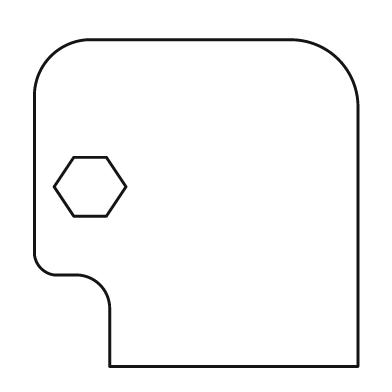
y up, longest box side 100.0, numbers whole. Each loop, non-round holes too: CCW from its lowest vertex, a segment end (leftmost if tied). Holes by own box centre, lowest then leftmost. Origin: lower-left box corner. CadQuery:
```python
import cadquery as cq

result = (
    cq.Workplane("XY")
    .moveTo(23.0, 0.0)
    .lineTo(99.0, 0.0)
    .lineTo(99.0, 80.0)
    .threePointArc((93.0, 94.0), (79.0, 100.0))
    .lineTo(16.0, 100.0)
    .threePointArc((5.0, 95.0), (0.0, 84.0))
    .lineTo(0.0, 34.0)
    .threePointArc((2.0, 30.0), (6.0, 28.0))
    .lineTo(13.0, 28.0)
    .threePointArc((20.0, 25.0), (23.0, 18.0))
    .close()
    .moveTo(12.0, 46.0)
    .lineTo(22.0, 46.0)
    .lineTo(28.0, 55.0)
    .lineTo(22.0, 64.0)
    .lineTo(12.0, 64.0)
    .lineTo(6.0, 55.0)
    .close()
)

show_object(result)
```